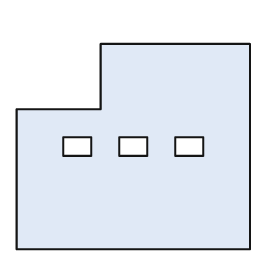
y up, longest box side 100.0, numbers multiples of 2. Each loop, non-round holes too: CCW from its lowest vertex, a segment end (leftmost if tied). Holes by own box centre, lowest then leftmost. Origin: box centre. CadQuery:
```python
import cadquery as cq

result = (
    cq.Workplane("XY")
    .moveTo(-50.0, -44.0)
    .lineTo(50.0, -44.0)
    .lineTo(50.0, 44.0)
    .lineTo(-14.0, 44.0)
    .lineTo(-14.0, 16.0)
    .lineTo(-50.0, 16.0)
    .close()
    .moveTo(-30.0, -4.0)
    .lineTo(-18.0, -4.0)
    .lineTo(-18.0, 4.0)
    .lineTo(-30.0, 4.0)
    .close()
    .moveTo(-6.0, -4.0)
    .lineTo(6.0, -4.0)
    .lineTo(6.0, 4.0)
    .lineTo(-6.0, 4.0)
    .close()
    .moveTo(18.0, -4.0)
    .lineTo(30.0, -4.0)
    .lineTo(30.0, 4.0)
    .lineTo(18.0, 4.0)
    .close()
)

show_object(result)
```